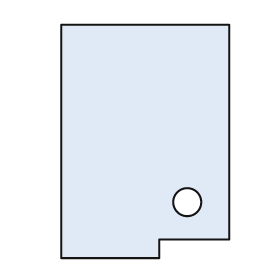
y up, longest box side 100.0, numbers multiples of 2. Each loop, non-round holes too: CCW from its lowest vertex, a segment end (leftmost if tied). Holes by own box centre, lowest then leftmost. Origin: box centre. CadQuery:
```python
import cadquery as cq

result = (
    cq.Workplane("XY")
    .moveTo(-36.0, -50.0)
    .lineTo(6.0, -50.0)
    .lineTo(6.0, -42.0)
    .lineTo(36.0, -42.0)
    .lineTo(36.0, 50.0)
    .lineTo(-36.0, 50.0)
    .close()
    .moveTo(18.0, -26.0)
    .circle(6.0)
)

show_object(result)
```